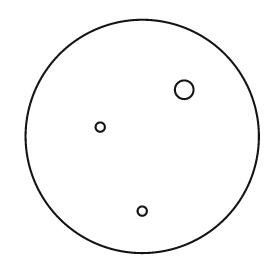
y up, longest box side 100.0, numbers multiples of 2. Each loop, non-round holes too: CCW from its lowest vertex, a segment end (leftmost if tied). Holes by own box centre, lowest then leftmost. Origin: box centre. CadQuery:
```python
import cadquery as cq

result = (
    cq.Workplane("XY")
    .moveTo(0.0, 0.0)
    .circle(50.0)
    .moveTo(0.0, -32.0)
    .circle(2.0)
    .moveTo(-18.0, 4.0)
    .circle(2.0)
    .moveTo(18.0, 20.0)
    .circle(4.0)
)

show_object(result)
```